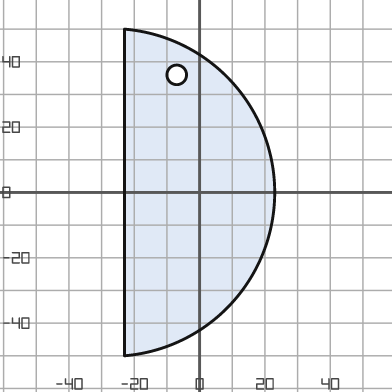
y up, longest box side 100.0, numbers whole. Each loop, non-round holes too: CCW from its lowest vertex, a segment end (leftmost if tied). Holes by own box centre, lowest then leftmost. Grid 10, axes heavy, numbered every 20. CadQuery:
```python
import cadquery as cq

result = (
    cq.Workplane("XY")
    .moveTo(-23.0, -50.0)
    .threePointArc((23.0, 0.0), (-23.0, 50.0))
    .close()
    .moveTo(-7.0, 36.0)
    .circle(3.0)
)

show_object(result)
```